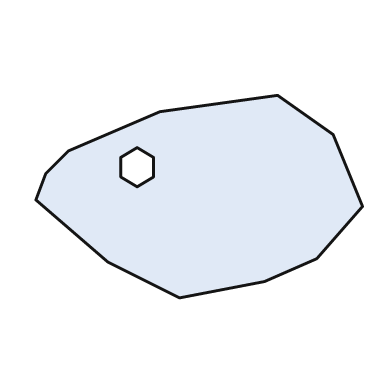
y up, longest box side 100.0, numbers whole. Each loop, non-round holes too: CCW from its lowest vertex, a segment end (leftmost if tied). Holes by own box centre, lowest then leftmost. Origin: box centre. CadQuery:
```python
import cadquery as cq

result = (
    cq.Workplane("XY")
    .moveTo(-6.0, -31.0)
    .lineTo(20.0, -26.0)
    .lineTo(36.0, -19.0)
    .lineTo(50.0, -3.0)
    .lineTo(41.0, 19.0)
    .lineTo(24.0, 31.0)
    .lineTo(-12.0, 26.0)
    .lineTo(-40.0, 14.0)
    .lineTo(-47.0, 7.0)
    .lineTo(-50.0, -1.0)
    .lineTo(-28.0, -20.0)
    .close()
    .moveTo(-19.0, 3.0)
    .lineTo(-14.0, 6.0)
    .lineTo(-14.0, 12.0)
    .lineTo(-19.0, 15.0)
    .lineTo(-24.0, 12.0)
    .lineTo(-24.0, 6.0)
    .close()
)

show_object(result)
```